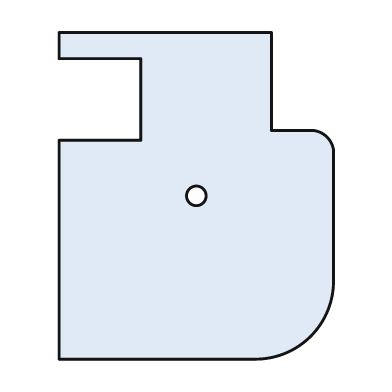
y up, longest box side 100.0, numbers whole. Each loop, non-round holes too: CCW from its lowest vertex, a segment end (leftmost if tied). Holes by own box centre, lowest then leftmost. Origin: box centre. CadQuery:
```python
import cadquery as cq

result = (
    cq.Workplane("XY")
    .moveTo(-42.0, -50.0)
    .lineTo(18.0, -50.0)
    .threePointArc((35.0, -43.0), (42.0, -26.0))
    .lineTo(42.0, 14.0)
    .threePointArc((40.0, 18.0), (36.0, 20.0))
    .lineTo(23.0, 20.0)
    .lineTo(23.0, 50.0)
    .lineTo(-42.0, 50.0)
    .lineTo(-42.0, 42.0)
    .lineTo(-17.0, 42.0)
    .lineTo(-17.0, 17.0)
    .lineTo(-42.0, 17.0)
    .close()
    .moveTo(0.0, 0.0)
    .circle(3.0)
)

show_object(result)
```